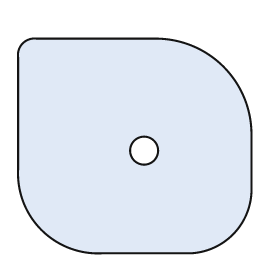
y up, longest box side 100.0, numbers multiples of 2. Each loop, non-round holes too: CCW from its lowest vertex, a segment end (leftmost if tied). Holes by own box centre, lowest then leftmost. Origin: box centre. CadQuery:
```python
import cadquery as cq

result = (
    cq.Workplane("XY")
    .moveTo(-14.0, -46.0)
    .lineTo(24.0, -46.0)
    .threePointArc((42.0, -38.0), (50.0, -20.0))
    .lineTo(50.0, 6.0)
    .threePointArc((38.0, 34.0), (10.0, 46.0))
    .lineTo(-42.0, 46.0)
    .threePointArc((-48.0, 44.0), (-50.0, 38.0))
    .lineTo(-50.0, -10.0)
    .threePointArc((-40.0, -36.0), (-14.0, -46.0))
    .close()
    .moveTo(4.0, -2.0)
    .circle(6.0)
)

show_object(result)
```